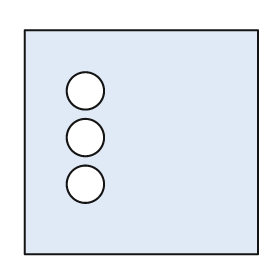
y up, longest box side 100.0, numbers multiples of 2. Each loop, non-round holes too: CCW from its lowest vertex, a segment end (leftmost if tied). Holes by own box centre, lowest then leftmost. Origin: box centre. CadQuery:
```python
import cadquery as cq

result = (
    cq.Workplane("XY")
    .moveTo(-50.0, -48.0)
    .lineTo(50.0, -48.0)
    .lineTo(50.0, 48.0)
    .lineTo(-50.0, 48.0)
    .close()
    .moveTo(-24.0, -18.0)
    .circle(8.0)
    .moveTo(-24.0, 2.0)
    .circle(8.0)
    .moveTo(-24.0, 22.0)
    .circle(8.0)
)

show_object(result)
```